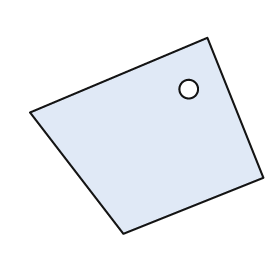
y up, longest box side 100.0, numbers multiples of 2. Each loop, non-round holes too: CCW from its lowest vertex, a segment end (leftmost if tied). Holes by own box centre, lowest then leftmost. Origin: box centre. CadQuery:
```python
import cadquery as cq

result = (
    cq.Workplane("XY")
    .moveTo(-10.0, -42.0)
    .lineTo(50.0, -18.0)
    .lineTo(26.0, 42.0)
    .lineTo(-50.0, 10.0)
    .close()
    .moveTo(18.0, 20.0)
    .circle(4.0)
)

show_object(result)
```